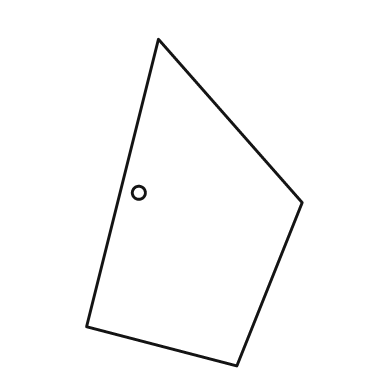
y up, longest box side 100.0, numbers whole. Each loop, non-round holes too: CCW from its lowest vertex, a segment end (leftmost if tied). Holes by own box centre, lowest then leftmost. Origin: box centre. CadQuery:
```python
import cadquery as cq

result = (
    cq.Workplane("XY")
    .moveTo(13.0, -50.0)
    .lineTo(33.0, 0.0)
    .lineTo(-11.0, 50.0)
    .lineTo(-33.0, -38.0)
    .close()
    .moveTo(-17.0, 3.0)
    .circle(2.0)
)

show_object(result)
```